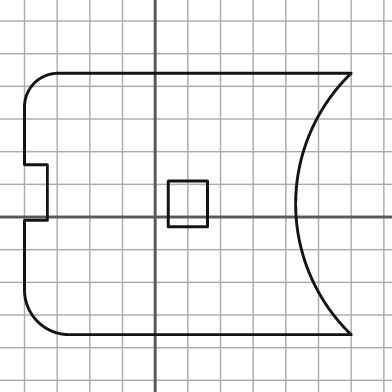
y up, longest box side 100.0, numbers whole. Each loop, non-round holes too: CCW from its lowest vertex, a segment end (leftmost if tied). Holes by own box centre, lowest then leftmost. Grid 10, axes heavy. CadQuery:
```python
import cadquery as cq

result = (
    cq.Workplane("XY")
    .moveTo(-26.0, -36.0)
    .lineTo(60.0, -36.0)
    .threePointArc((43.0, 4.0), (60.0, 44.0))
    .lineTo(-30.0, 44.0)
    .threePointArc((-37.0, 41.0), (-40.0, 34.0))
    .lineTo(-40.0, 16.0)
    .lineTo(-33.0, 16.0)
    .lineTo(-33.0, -1.0)
    .lineTo(-40.0, -1.0)
    .lineTo(-40.0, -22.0)
    .threePointArc((-36.0, -32.0), (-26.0, -36.0))
    .close()
    .moveTo(4.0, -3.0)
    .lineTo(16.0, -3.0)
    .lineTo(16.0, 11.0)
    .lineTo(4.0, 11.0)
    .close()
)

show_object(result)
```